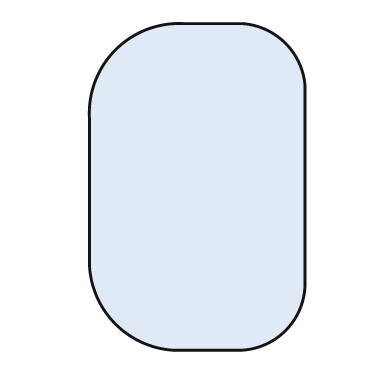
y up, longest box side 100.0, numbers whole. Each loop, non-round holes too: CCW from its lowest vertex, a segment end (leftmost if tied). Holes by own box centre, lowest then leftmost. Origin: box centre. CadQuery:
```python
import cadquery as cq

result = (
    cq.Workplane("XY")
    .moveTo(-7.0, -50.0)
    .lineTo(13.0, -50.0)
    .threePointArc((27.0, -44.0), (33.0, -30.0))
    .lineTo(33.0, 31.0)
    .threePointArc((27.0, 44.0), (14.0, 50.0))
    .lineTo(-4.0, 50.0)
    .threePointArc((-25.0, 42.0), (-33.0, 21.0))
    .lineTo(-33.0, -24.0)
    .threePointArc((-25.0, -42.0), (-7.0, -50.0))
    .close()
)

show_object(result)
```